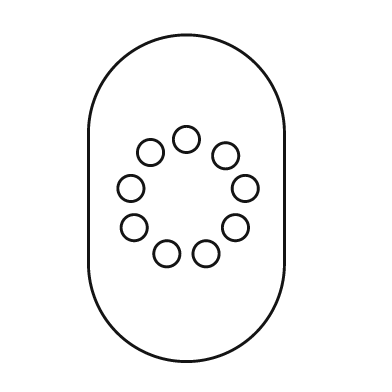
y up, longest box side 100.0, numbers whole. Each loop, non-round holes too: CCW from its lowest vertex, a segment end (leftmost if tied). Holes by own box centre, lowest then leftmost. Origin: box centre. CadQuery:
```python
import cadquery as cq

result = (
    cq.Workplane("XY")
    .moveTo(-30.0, -20.0)
    .threePointArc((0.0, -50.0), (30.0, -20.0))
    .lineTo(30.0, 20.0)
    .threePointArc((0.0, 50.0), (-30.0, 20.0))
    .close()
    .moveTo(-6.0, -17.0)
    .circle(4.0)
    .moveTo(6.0, -17.0)
    .circle(4.0)
    .moveTo(-16.0, -9.0)
    .circle(4.0)
    .moveTo(15.0, -9.0)
    .circle(4.0)
    .moveTo(-17.0, 3.0)
    .circle(4.0)
    .moveTo(18.0, 3.0)
    .circle(4.0)
    .moveTo(12.0, 13.0)
    .circle(4.0)
    .moveTo(-11.0, 14.0)
    .circle(4.0)
    .moveTo(0.0, 18.0)
    .circle(4.0)
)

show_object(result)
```